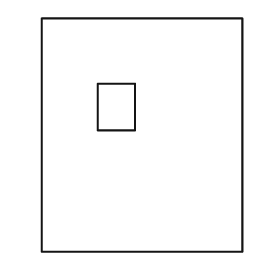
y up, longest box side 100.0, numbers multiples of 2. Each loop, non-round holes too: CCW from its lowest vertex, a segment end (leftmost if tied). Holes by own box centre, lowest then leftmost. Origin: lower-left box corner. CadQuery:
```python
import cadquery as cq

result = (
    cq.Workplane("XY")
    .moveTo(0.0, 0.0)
    .lineTo(86.0, 0.0)
    .lineTo(86.0, 100.0)
    .lineTo(0.0, 100.0)
    .close()
    .moveTo(24.0, 52.0)
    .lineTo(40.0, 52.0)
    .lineTo(40.0, 72.0)
    .lineTo(24.0, 72.0)
    .close()
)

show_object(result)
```